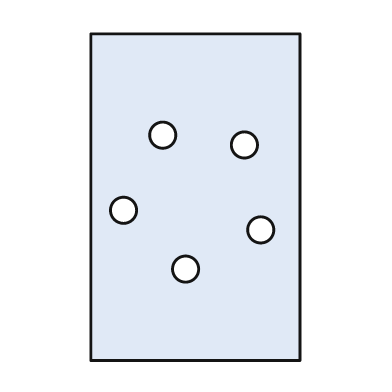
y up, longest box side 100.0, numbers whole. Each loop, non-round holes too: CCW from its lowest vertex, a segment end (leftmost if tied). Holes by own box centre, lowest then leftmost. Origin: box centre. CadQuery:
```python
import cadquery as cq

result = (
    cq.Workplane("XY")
    .moveTo(-32.0, -50.0)
    .lineTo(32.0, -50.0)
    .lineTo(32.0, 50.0)
    .lineTo(-32.0, 50.0)
    .close()
    .moveTo(-3.0, -22.0)
    .circle(4.0)
    .moveTo(20.0, -10.0)
    .circle(4.0)
    .moveTo(-22.0, -4.0)
    .circle(4.0)
    .moveTo(15.0, 16.0)
    .circle(4.0)
    .moveTo(-10.0, 19.0)
    .circle(4.0)
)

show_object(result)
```